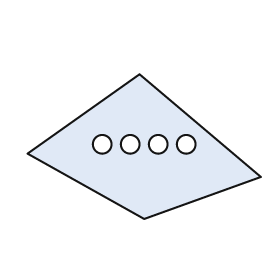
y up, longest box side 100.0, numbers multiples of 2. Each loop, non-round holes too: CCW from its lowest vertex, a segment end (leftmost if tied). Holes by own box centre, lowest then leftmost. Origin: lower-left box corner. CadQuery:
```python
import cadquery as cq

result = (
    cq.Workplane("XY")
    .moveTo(50.0, 0.0)
    .lineTo(100.0, 18.0)
    .lineTo(48.0, 62.0)
    .lineTo(0.0, 28.0)
    .close()
    .moveTo(32.0, 32.0)
    .circle(4.0)
    .moveTo(44.0, 32.0)
    .circle(4.0)
    .moveTo(56.0, 32.0)
    .circle(4.0)
    .moveTo(68.0, 32.0)
    .circle(4.0)
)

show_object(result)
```